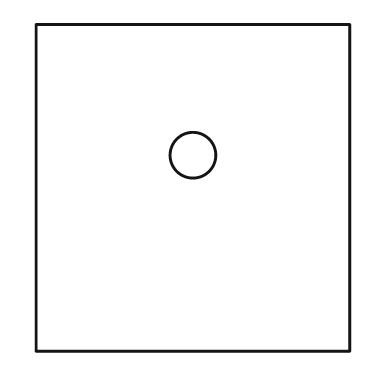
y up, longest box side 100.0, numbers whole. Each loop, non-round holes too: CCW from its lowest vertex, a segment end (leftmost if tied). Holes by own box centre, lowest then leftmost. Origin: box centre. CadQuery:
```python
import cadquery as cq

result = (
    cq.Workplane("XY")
    .moveTo(-48.0, -50.0)
    .lineTo(48.0, -50.0)
    .lineTo(48.0, 50.0)
    .lineTo(-48.0, 50.0)
    .close()
    .moveTo(0.0, 10.0)
    .circle(7.0)
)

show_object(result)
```